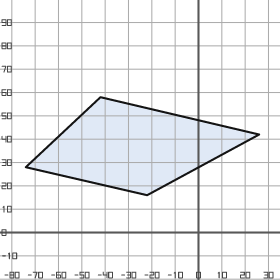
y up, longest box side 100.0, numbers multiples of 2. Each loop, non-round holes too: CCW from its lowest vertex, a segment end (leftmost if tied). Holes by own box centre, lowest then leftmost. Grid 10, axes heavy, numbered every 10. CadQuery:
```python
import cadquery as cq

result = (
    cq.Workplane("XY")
    .moveTo(-22.0, 16.0)
    .lineTo(26.0, 42.0)
    .lineTo(-42.0, 58.0)
    .lineTo(-74.0, 28.0)
    .close()
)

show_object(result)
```